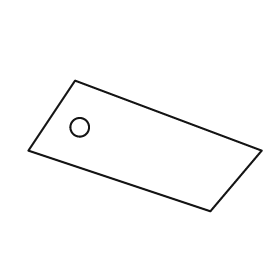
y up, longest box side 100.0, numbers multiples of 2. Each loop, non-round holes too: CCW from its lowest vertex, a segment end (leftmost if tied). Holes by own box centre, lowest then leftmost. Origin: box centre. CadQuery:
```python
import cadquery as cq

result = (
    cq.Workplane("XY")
    .moveTo(28.0, -28.0)
    .lineTo(50.0, -2.0)
    .lineTo(-30.0, 28.0)
    .lineTo(-50.0, -2.0)
    .close()
    .moveTo(-28.0, 8.0)
    .circle(4.0)
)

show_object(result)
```